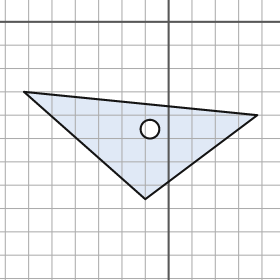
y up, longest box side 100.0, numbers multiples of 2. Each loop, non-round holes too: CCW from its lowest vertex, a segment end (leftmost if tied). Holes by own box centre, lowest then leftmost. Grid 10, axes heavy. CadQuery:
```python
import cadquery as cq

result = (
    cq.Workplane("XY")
    .moveTo(-10.0, -76.0)
    .lineTo(38.0, -40.0)
    .lineTo(-62.0, -30.0)
    .close()
    .moveTo(-8.0, -46.0)
    .circle(4.0)
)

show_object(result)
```